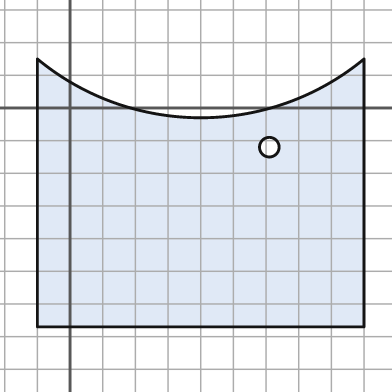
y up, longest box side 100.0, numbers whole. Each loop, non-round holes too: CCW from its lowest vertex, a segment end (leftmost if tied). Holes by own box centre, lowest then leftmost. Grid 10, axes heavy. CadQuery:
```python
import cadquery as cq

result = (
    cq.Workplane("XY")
    .moveTo(-10.0, -67.0)
    .lineTo(90.0, -67.0)
    .lineTo(90.0, 15.0)
    .threePointArc((40.0, -3.0), (-10.0, 15.0))
    .close()
    .moveTo(61.0, -12.0)
    .circle(3.0)
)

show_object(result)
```